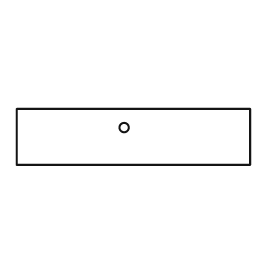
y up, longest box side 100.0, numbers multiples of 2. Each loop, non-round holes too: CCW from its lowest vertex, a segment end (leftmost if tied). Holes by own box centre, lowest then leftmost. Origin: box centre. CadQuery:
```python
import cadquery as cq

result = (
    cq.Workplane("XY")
    .moveTo(-50.0, -12.0)
    .lineTo(50.0, -12.0)
    .lineTo(50.0, 12.0)
    .lineTo(-50.0, 12.0)
    .close()
    .moveTo(-4.0, 4.0)
    .circle(2.0)
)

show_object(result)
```